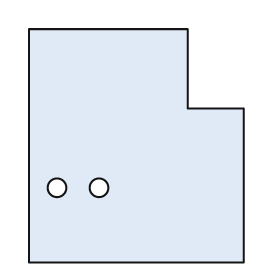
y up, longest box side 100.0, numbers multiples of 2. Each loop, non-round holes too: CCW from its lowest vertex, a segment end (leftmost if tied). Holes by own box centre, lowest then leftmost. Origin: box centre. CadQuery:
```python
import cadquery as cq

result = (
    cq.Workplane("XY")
    .moveTo(-46.0, -50.0)
    .lineTo(46.0, -50.0)
    .lineTo(46.0, 16.0)
    .lineTo(22.0, 16.0)
    .lineTo(22.0, 50.0)
    .lineTo(-46.0, 50.0)
    .close()
    .moveTo(-34.0, -18.0)
    .circle(4.0)
    .moveTo(-16.0, -18.0)
    .circle(4.0)
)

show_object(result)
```